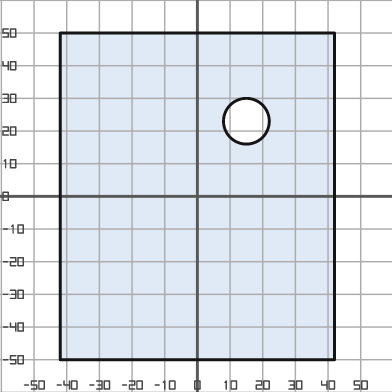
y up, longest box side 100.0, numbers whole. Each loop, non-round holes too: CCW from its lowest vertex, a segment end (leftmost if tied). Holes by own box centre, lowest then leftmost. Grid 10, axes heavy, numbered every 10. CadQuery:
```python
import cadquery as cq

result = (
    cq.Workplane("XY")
    .moveTo(-42.0, -50.0)
    .lineTo(42.0, -50.0)
    .lineTo(42.0, 50.0)
    .lineTo(-42.0, 50.0)
    .close()
    .moveTo(15.0, 23.0)
    .circle(7.0)
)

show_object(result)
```